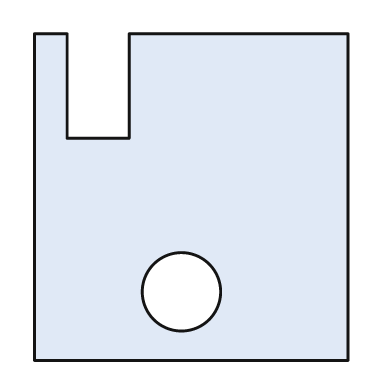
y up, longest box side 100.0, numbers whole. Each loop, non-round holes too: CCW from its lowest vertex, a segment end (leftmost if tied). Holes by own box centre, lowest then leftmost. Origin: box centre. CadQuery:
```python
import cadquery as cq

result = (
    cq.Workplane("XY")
    .moveTo(-48.0, -50.0)
    .lineTo(48.0, -50.0)
    .lineTo(48.0, 50.0)
    .lineTo(-19.0, 50.0)
    .lineTo(-19.0, 18.0)
    .lineTo(-38.0, 18.0)
    .lineTo(-38.0, 50.0)
    .lineTo(-48.0, 50.0)
    .close()
    .moveTo(-3.0, -29.0)
    .circle(12.0)
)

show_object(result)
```